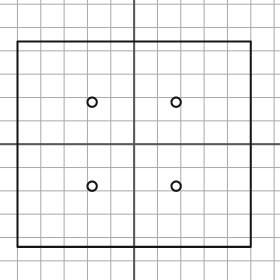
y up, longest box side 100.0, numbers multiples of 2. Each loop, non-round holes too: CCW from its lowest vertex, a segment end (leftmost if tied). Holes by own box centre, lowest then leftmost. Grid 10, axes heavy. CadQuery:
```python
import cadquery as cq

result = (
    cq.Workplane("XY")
    .moveTo(-50.0, -44.0)
    .lineTo(50.0, -44.0)
    .lineTo(50.0, 44.0)
    .lineTo(-50.0, 44.0)
    .close()
    .moveTo(-18.0, -18.0)
    .circle(2.0)
    .moveTo(18.0, -18.0)
    .circle(2.0)
    .moveTo(-18.0, 18.0)
    .circle(2.0)
    .moveTo(18.0, 18.0)
    .circle(2.0)
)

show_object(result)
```